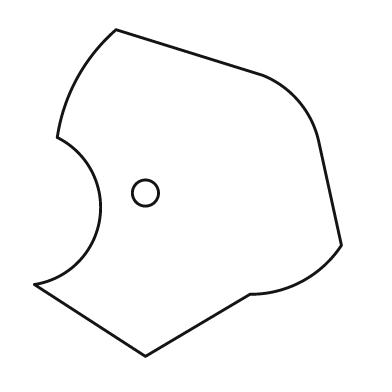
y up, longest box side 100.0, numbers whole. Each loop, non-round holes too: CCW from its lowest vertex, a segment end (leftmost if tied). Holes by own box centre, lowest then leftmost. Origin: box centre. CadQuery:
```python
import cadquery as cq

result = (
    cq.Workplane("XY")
    .moveTo(-13.0, -50.0)
    .lineTo(19.0, -31.0)
    .threePointArc((35.0, -27.0), (47.0, -16.0))
    .lineTo(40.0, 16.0)
    .threePointArc((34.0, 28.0), (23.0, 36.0))
    .lineTo(-22.0, 50.0)
    .threePointArc((-34.0, 35.0), (-40.0, 17.0))
    .threePointArc((-27.0, -8.0), (-47.0, -28.0))
    .close()
    .moveTo(-13.0, 0.0)
    .circle(4.0)
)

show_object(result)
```